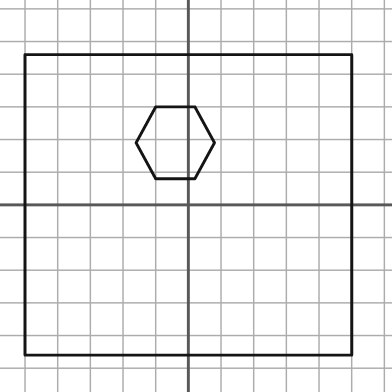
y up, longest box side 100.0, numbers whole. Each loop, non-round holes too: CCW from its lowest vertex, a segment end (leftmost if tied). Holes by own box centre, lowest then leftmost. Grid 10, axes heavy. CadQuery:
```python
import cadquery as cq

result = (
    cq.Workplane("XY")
    .moveTo(-50.0, -46.0)
    .lineTo(50.0, -46.0)
    .lineTo(50.0, 46.0)
    .lineTo(-50.0, 46.0)
    .close()
    .moveTo(-10.0, 8.0)
    .lineTo(2.0, 8.0)
    .lineTo(8.0, 19.0)
    .lineTo(2.0, 30.0)
    .lineTo(-10.0, 30.0)
    .lineTo(-16.0, 19.0)
    .close()
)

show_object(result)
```